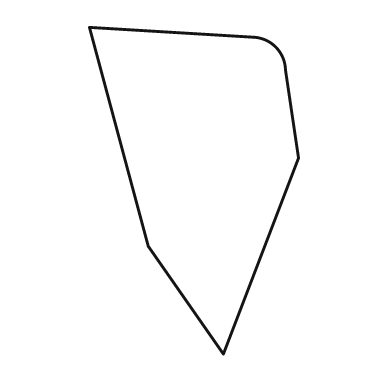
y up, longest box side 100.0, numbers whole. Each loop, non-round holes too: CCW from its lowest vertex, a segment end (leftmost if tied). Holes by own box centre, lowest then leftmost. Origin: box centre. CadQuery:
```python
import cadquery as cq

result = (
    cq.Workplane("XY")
    .moveTo(9.0, -50.0)
    .lineTo(32.0, 10.0)
    .lineTo(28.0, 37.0)
    .threePointArc((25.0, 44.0), (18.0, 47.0))
    .lineTo(-32.0, 50.0)
    .lineTo(-14.0, -17.0)
    .close()
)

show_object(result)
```